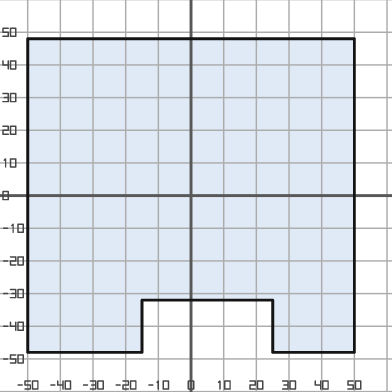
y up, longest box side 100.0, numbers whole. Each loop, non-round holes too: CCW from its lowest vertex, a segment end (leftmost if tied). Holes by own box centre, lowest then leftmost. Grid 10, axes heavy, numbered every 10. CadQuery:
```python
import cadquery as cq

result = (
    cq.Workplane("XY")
    .moveTo(-50.0, -48.0)
    .lineTo(-15.0, -48.0)
    .lineTo(-15.0, -32.0)
    .lineTo(25.0, -32.0)
    .lineTo(25.0, -48.0)
    .lineTo(50.0, -48.0)
    .lineTo(50.0, 48.0)
    .lineTo(-50.0, 48.0)
    .close()
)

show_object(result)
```